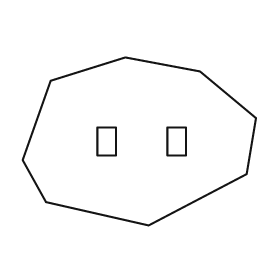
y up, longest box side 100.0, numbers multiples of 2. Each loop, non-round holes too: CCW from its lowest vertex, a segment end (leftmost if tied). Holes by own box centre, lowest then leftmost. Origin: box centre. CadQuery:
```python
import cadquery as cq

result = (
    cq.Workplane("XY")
    .moveTo(4.0, -36.0)
    .lineTo(46.0, -14.0)
    .lineTo(50.0, 10.0)
    .lineTo(26.0, 30.0)
    .lineTo(-6.0, 36.0)
    .lineTo(-38.0, 26.0)
    .lineTo(-50.0, -8.0)
    .lineTo(-40.0, -26.0)
    .close()
    .moveTo(-18.0, -6.0)
    .lineTo(-10.0, -6.0)
    .lineTo(-10.0, 6.0)
    .lineTo(-18.0, 6.0)
    .close()
    .moveTo(12.0, -6.0)
    .lineTo(20.0, -6.0)
    .lineTo(20.0, 6.0)
    .lineTo(12.0, 6.0)
    .close()
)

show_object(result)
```